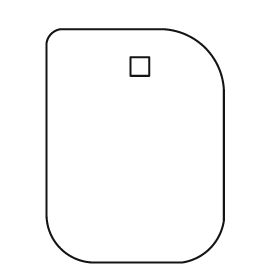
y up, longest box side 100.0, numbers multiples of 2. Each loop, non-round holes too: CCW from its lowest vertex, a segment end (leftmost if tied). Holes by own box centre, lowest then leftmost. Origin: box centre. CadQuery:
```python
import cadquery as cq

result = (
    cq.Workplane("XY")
    .moveTo(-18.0, -50.0)
    .lineTo(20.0, -50.0)
    .threePointArc((32.0, -44.0), (38.0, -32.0))
    .lineTo(38.0, 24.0)
    .threePointArc((30.0, 42.0), (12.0, 50.0))
    .lineTo(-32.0, 50.0)
    .threePointArc((-36.0, 48.0), (-38.0, 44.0))
    .lineTo(-38.0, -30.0)
    .threePointArc((-32.0, -44.0), (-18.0, -50.0))
    .close()
    .moveTo(-2.0, 30.0)
    .lineTo(6.0, 30.0)
    .lineTo(6.0, 38.0)
    .lineTo(-2.0, 38.0)
    .close()
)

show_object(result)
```